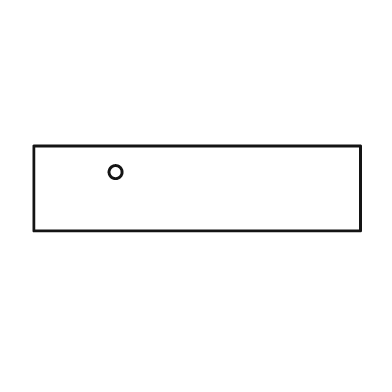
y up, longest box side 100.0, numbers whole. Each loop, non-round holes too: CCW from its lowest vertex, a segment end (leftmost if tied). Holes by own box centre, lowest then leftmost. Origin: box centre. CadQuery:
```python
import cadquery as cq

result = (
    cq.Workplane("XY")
    .moveTo(-50.0, -13.0)
    .lineTo(50.0, -13.0)
    .lineTo(50.0, 13.0)
    .lineTo(-50.0, 13.0)
    .close()
    .moveTo(-25.0, 5.0)
    .circle(2.0)
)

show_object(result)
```